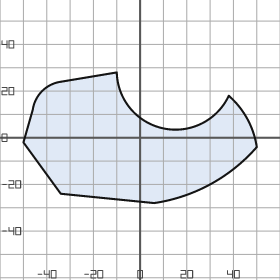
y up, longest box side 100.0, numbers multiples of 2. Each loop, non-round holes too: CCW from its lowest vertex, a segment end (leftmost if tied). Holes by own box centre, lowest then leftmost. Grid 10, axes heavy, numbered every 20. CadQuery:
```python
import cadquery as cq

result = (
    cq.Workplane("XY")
    .moveTo(6.0, -28.0)
    .threePointArc((30.0, -20.0), (50.0, -4.0))
    .threePointArc((46.0, 8.0), (38.0, 18.0))
    .threePointArc((10.0, 4.0), (-10.0, 28.0))
    .lineTo(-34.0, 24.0)
    .threePointArc((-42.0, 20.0), (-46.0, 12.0))
    .lineTo(-50.0, -2.0)
    .lineTo(-34.0, -24.0)
    .close()
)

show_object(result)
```